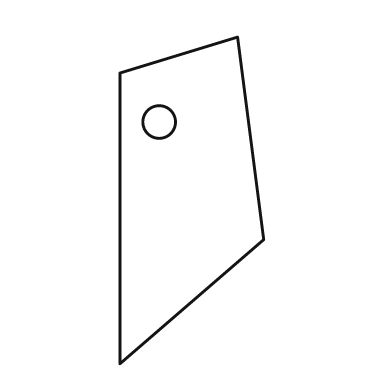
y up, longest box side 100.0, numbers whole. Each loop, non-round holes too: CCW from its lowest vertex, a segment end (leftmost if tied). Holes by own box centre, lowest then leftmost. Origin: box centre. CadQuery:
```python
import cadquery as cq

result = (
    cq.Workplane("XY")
    .moveTo(-22.0, -50.0)
    .lineTo(22.0, -12.0)
    .lineTo(14.0, 50.0)
    .lineTo(-22.0, 39.0)
    .close()
    .moveTo(-10.0, 24.0)
    .circle(5.0)
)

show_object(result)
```